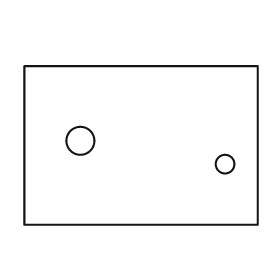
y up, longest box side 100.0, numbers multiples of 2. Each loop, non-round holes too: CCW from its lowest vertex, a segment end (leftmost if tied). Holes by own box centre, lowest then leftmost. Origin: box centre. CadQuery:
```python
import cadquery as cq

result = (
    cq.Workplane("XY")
    .moveTo(-50.0, -34.0)
    .lineTo(50.0, -34.0)
    .lineTo(50.0, 34.0)
    .lineTo(-50.0, 34.0)
    .close()
    .moveTo(36.0, -8.0)
    .circle(4.0)
    .moveTo(-26.0, 2.0)
    .circle(6.0)
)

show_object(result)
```